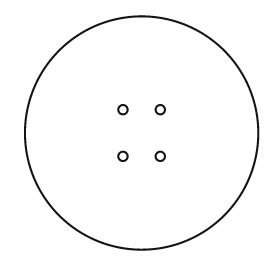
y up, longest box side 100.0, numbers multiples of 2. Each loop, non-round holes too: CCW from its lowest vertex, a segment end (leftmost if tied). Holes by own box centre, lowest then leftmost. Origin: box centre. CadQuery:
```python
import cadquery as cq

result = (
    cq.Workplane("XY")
    .moveTo(0.0, 0.0)
    .circle(50.0)
    .moveTo(-8.0, -10.0)
    .circle(2.0)
    .moveTo(8.0, -10.0)
    .circle(2.0)
    .moveTo(-8.0, 10.0)
    .circle(2.0)
    .moveTo(8.0, 10.0)
    .circle(2.0)
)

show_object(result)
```